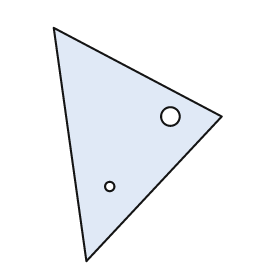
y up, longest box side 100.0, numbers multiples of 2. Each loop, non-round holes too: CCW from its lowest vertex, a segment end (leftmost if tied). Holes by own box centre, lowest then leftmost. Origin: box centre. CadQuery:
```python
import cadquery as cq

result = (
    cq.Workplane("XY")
    .moveTo(-22.0, -50.0)
    .lineTo(36.0, 12.0)
    .lineTo(-36.0, 50.0)
    .close()
    .moveTo(-12.0, -18.0)
    .circle(2.0)
    .moveTo(14.0, 12.0)
    .circle(4.0)
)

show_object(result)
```